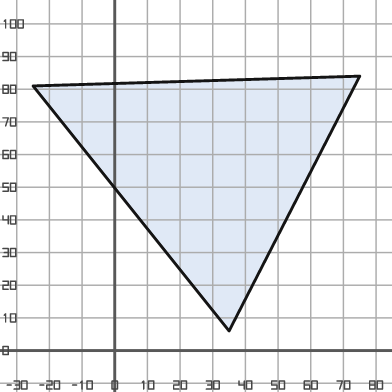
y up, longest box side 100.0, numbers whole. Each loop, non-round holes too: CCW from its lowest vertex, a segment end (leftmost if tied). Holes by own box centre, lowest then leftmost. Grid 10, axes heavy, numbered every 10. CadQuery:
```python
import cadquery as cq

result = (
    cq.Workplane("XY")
    .moveTo(35.0, 6.0)
    .lineTo(75.0, 84.0)
    .lineTo(-25.0, 81.0)
    .close()
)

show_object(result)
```